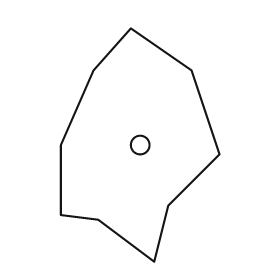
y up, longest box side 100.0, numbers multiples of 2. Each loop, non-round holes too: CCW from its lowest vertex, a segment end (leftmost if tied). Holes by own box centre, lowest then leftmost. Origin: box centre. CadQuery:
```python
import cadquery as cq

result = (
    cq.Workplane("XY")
    .moveTo(6.0, -50.0)
    .lineTo(12.0, -26.0)
    .lineTo(34.0, -4.0)
    .lineTo(22.0, 32.0)
    .lineTo(-4.0, 50.0)
    .lineTo(-20.0, 32.0)
    .lineTo(-34.0, 0.0)
    .lineTo(-34.0, -30.0)
    .lineTo(-18.0, -32.0)
    .close()
    .moveTo(0.0, 0.0)
    .circle(4.0)
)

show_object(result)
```